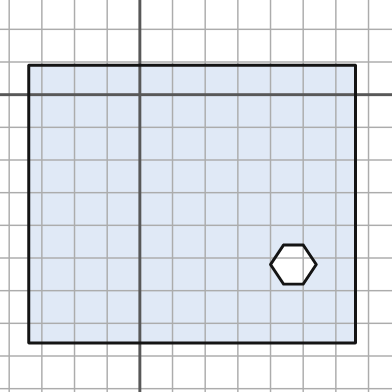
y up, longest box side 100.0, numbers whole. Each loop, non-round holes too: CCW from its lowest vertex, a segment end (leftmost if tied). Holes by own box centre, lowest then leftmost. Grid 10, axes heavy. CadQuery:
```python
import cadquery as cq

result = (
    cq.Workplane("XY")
    .moveTo(-34.0, -76.0)
    .lineTo(66.0, -76.0)
    .lineTo(66.0, 9.0)
    .lineTo(-34.0, 9.0)
    .close()
    .moveTo(44.0, -58.0)
    .lineTo(50.0, -58.0)
    .lineTo(54.0, -52.0)
    .lineTo(50.0, -46.0)
    .lineTo(44.0, -46.0)
    .lineTo(40.0, -52.0)
    .close()
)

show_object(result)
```